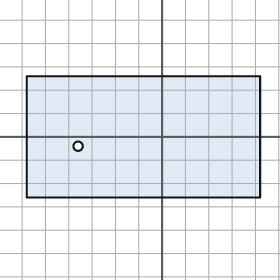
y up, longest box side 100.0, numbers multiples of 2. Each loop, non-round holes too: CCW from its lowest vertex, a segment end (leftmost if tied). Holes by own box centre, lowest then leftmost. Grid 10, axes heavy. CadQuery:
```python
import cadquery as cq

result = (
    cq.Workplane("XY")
    .moveTo(-58.0, -26.0)
    .lineTo(42.0, -26.0)
    .lineTo(42.0, 26.0)
    .lineTo(-58.0, 26.0)
    .close()
    .moveTo(-36.0, -4.0)
    .circle(2.0)
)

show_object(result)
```